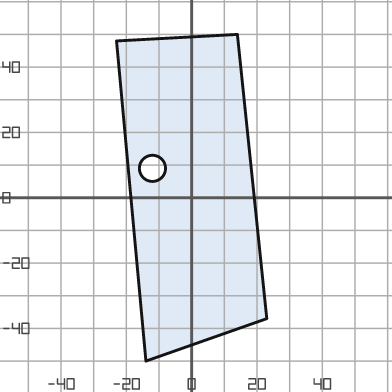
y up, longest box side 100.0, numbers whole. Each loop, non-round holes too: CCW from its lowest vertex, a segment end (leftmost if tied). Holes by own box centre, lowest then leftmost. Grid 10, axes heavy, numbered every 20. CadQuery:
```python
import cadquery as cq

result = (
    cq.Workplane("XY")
    .moveTo(-14.0, -50.0)
    .lineTo(23.0, -37.0)
    .lineTo(14.0, 50.0)
    .lineTo(-23.0, 48.0)
    .close()
    .moveTo(-12.0, 9.0)
    .circle(4.0)
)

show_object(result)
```